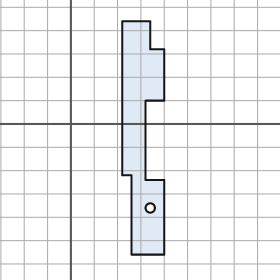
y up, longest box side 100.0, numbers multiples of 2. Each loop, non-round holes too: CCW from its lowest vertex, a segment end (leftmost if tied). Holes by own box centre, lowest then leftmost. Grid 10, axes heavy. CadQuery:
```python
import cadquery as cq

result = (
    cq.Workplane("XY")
    .moveTo(26.0, -56.0)
    .lineTo(40.0, -56.0)
    .lineTo(40.0, -24.0)
    .lineTo(32.0, -24.0)
    .lineTo(32.0, 10.0)
    .lineTo(40.0, 10.0)
    .lineTo(40.0, 32.0)
    .lineTo(34.0, 32.0)
    .lineTo(34.0, 44.0)
    .lineTo(22.0, 44.0)
    .lineTo(22.0, -22.0)
    .lineTo(26.0, -22.0)
    .close()
    .moveTo(34.0, -36.0)
    .circle(2.0)
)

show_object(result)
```